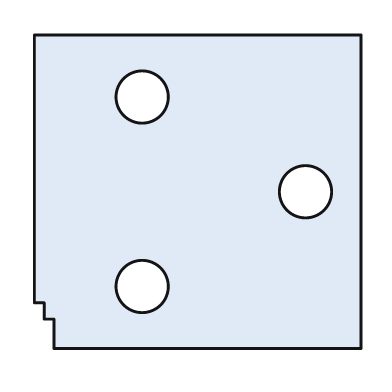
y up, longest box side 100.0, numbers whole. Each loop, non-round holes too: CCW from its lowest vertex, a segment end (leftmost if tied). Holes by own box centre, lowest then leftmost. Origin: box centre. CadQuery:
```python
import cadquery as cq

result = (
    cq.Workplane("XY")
    .moveTo(-44.0, -48.0)
    .lineTo(50.0, -48.0)
    .lineTo(50.0, 48.0)
    .lineTo(-50.0, 48.0)
    .lineTo(-50.0, -34.0)
    .lineTo(-47.0, -34.0)
    .lineTo(-47.0, -39.0)
    .lineTo(-44.0, -39.0)
    .close()
    .moveTo(-17.0, -29.0)
    .circle(8.0)
    .moveTo(33.0, 0.0)
    .circle(8.0)
    .moveTo(-17.0, 29.0)
    .circle(8.0)
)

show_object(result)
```